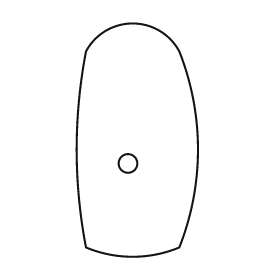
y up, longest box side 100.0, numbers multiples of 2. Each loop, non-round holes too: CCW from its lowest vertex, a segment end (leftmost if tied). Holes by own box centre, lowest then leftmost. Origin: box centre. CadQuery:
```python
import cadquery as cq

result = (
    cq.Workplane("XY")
    .moveTo(-22.0, -46.0)
    .threePointArc((-2.0, -50.0), (18.0, -46.0))
    .threePointArc((26.0, -4.0), (18.0, 38.0))
    .threePointArc((-2.0, 50.0), (-22.0, 38.0))
    .threePointArc((-26.0, -4.0), (-22.0, -46.0))
    .close()
    .moveTo(-4.0, -10.0)
    .circle(4.0)
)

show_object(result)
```